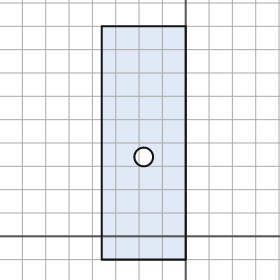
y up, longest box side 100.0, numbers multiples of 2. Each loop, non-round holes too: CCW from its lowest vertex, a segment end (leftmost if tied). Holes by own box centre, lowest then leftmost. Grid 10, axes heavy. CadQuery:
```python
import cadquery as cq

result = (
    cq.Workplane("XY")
    .moveTo(-36.0, -10.0)
    .lineTo(0.0, -10.0)
    .lineTo(0.0, 90.0)
    .lineTo(-36.0, 90.0)
    .close()
    .moveTo(-18.0, 34.0)
    .circle(4.0)
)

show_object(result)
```